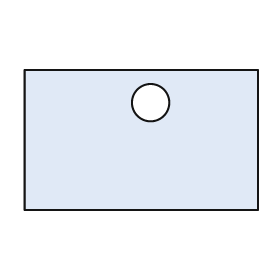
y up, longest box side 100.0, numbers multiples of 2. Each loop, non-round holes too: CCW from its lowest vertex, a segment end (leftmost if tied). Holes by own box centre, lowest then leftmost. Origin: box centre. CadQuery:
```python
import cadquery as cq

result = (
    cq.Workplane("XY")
    .moveTo(-50.0, -30.0)
    .lineTo(50.0, -30.0)
    .lineTo(50.0, 30.0)
    .lineTo(-50.0, 30.0)
    .close()
    .moveTo(4.0, 16.0)
    .circle(8.0)
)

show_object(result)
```